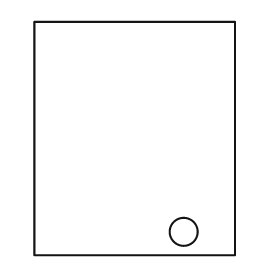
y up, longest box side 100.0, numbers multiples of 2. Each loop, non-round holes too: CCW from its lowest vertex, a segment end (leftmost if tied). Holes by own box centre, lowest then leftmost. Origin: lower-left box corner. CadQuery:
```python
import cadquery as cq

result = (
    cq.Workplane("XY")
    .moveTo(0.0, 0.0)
    .lineTo(86.0, 0.0)
    .lineTo(86.0, 100.0)
    .lineTo(0.0, 100.0)
    .close()
    .moveTo(64.0, 10.0)
    .circle(6.0)
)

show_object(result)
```